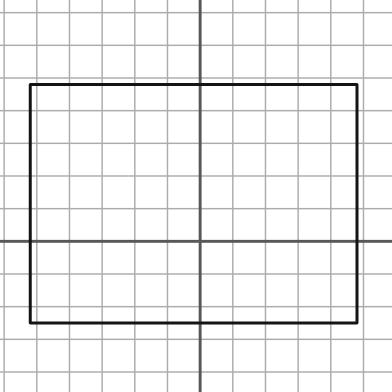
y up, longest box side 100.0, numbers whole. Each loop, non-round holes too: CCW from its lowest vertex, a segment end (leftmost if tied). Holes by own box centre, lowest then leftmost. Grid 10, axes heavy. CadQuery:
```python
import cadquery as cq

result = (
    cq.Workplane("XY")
    .moveTo(-52.0, -25.0)
    .lineTo(48.0, -25.0)
    .lineTo(48.0, 48.0)
    .lineTo(-52.0, 48.0)
    .close()
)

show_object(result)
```